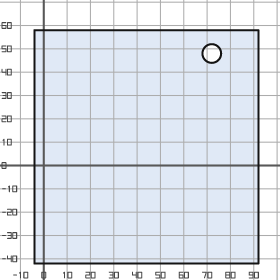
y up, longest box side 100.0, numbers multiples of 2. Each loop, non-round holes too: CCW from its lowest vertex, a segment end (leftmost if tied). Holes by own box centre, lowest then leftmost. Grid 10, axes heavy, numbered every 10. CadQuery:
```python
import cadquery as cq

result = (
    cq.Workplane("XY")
    .moveTo(-4.0, -42.0)
    .lineTo(92.0, -42.0)
    .lineTo(92.0, 58.0)
    .lineTo(-4.0, 58.0)
    .close()
    .moveTo(72.0, 48.0)
    .circle(4.0)
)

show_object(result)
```